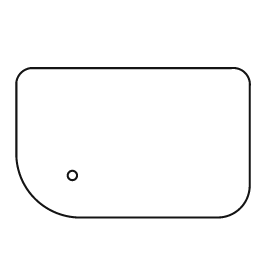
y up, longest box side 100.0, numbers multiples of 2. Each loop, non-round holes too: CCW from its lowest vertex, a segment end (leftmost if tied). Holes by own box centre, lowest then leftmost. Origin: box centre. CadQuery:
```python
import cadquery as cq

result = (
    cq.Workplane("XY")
    .moveTo(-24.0, -32.0)
    .lineTo(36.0, -32.0)
    .threePointArc((46.0, -28.0), (50.0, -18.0))
    .lineTo(50.0, 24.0)
    .threePointArc((48.0, 30.0), (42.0, 32.0))
    .lineTo(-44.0, 32.0)
    .threePointArc((-48.0, 30.0), (-50.0, 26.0))
    .lineTo(-50.0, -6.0)
    .threePointArc((-42.0, -24.0), (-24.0, -32.0))
    .close()
    .moveTo(-26.0, -14.0)
    .circle(2.0)
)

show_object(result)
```